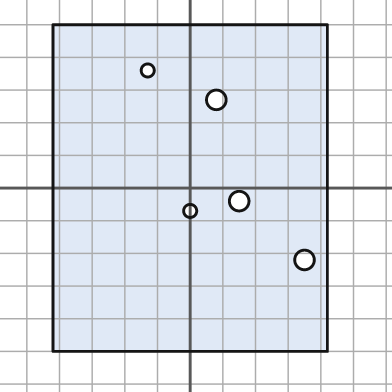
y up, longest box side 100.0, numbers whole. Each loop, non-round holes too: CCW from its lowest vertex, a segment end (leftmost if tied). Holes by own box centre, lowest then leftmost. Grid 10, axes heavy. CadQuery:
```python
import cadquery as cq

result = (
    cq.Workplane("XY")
    .moveTo(-42.0, -50.0)
    .lineTo(42.0, -50.0)
    .lineTo(42.0, 50.0)
    .lineTo(-42.0, 50.0)
    .close()
    .moveTo(35.0, -22.0)
    .circle(3.0)
    .moveTo(0.0, -7.0)
    .circle(2.0)
    .moveTo(15.0, -4.0)
    .circle(3.0)
    .moveTo(8.0, 27.0)
    .circle(3.0)
    .moveTo(-13.0, 36.0)
    .circle(2.0)
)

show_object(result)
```